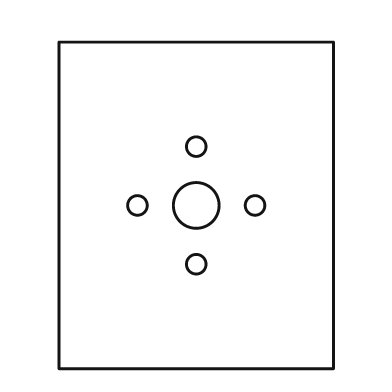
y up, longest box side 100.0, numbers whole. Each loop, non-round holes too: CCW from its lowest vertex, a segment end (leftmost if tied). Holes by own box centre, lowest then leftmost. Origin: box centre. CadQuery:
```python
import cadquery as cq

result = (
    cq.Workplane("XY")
    .moveTo(-42.0, -50.0)
    .lineTo(42.0, -50.0)
    .lineTo(42.0, 50.0)
    .lineTo(-42.0, 50.0)
    .close()
    .moveTo(0.0, -18.0)
    .circle(3.0)
    .moveTo(-18.0, 0.0)
    .circle(3.0)
    .moveTo(0.0, 0.0)
    .circle(7.0)
    .moveTo(18.0, 0.0)
    .circle(3.0)
    .moveTo(0.0, 18.0)
    .circle(3.0)
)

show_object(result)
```